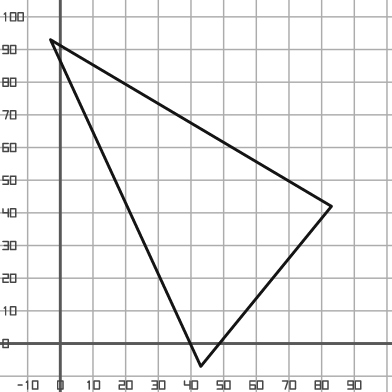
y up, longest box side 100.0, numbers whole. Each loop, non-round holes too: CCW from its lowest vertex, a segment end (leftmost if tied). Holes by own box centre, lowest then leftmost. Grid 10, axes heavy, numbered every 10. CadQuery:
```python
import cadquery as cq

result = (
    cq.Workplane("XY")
    .moveTo(43.0, -7.0)
    .lineTo(83.0, 42.0)
    .lineTo(-3.0, 93.0)
    .close()
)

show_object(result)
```